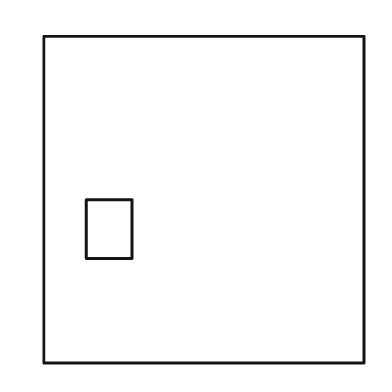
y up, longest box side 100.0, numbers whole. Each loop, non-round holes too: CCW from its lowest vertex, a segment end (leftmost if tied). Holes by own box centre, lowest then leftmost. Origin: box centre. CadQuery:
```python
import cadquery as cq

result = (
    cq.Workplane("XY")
    .moveTo(-49.0, -50.0)
    .lineTo(49.0, -50.0)
    .lineTo(49.0, 50.0)
    .lineTo(-49.0, 50.0)
    .close()
    .moveTo(-36.0, -18.0)
    .lineTo(-22.0, -18.0)
    .lineTo(-22.0, 0.0)
    .lineTo(-36.0, 0.0)
    .close()
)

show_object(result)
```